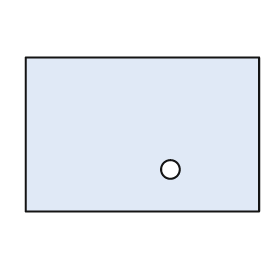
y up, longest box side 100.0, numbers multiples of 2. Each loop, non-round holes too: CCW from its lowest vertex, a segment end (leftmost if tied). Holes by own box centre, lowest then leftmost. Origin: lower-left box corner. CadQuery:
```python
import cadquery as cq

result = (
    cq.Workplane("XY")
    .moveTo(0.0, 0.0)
    .lineTo(100.0, 0.0)
    .lineTo(100.0, 66.0)
    .lineTo(0.0, 66.0)
    .close()
    .moveTo(62.0, 18.0)
    .circle(4.0)
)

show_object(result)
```